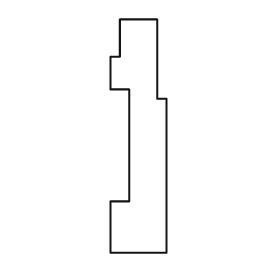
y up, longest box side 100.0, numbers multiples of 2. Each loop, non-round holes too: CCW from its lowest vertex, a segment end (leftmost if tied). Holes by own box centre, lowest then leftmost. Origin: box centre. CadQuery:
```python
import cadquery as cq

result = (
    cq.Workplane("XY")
    .moveTo(-12.0, -50.0)
    .lineTo(12.0, -50.0)
    .lineTo(12.0, 16.0)
    .lineTo(8.0, 16.0)
    .lineTo(8.0, 50.0)
    .lineTo(-8.0, 50.0)
    .lineTo(-8.0, 34.0)
    .lineTo(-12.0, 34.0)
    .lineTo(-12.0, 20.0)
    .lineTo(-4.0, 20.0)
    .lineTo(-4.0, -28.0)
    .lineTo(-12.0, -28.0)
    .close()
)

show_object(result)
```